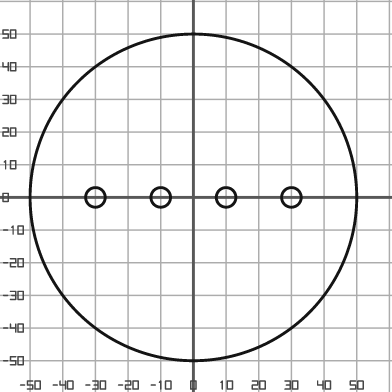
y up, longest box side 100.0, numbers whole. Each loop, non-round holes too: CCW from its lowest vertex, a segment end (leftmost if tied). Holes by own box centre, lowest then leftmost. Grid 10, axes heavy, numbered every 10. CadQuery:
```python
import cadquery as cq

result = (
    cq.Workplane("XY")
    .moveTo(0.0, 0.0)
    .circle(50.0)
    .moveTo(-30.0, 0.0)
    .circle(3.0)
    .moveTo(-10.0, 0.0)
    .circle(3.0)
    .moveTo(10.0, 0.0)
    .circle(3.0)
    .moveTo(30.0, 0.0)
    .circle(3.0)
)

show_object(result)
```